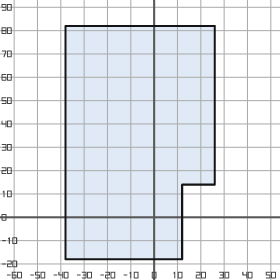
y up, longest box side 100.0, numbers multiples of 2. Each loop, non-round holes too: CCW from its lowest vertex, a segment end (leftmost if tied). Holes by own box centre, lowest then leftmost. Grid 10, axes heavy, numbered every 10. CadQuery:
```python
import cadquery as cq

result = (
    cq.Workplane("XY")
    .moveTo(-38.0, -18.0)
    .lineTo(12.0, -18.0)
    .lineTo(12.0, 14.0)
    .lineTo(26.0, 14.0)
    .lineTo(26.0, 82.0)
    .lineTo(-38.0, 82.0)
    .close()
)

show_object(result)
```